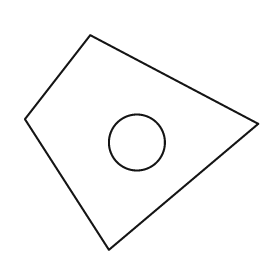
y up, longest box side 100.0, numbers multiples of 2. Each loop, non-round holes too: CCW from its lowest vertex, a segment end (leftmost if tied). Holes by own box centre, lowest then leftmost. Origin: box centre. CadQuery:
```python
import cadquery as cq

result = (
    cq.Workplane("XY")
    .moveTo(-14.0, -46.0)
    .lineTo(50.0, 8.0)
    .lineTo(-22.0, 46.0)
    .lineTo(-50.0, 10.0)
    .close()
    .moveTo(-2.0, 0.0)
    .circle(12.0)
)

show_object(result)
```